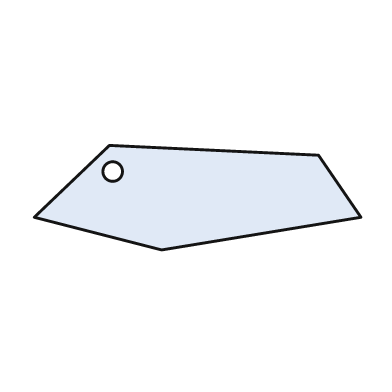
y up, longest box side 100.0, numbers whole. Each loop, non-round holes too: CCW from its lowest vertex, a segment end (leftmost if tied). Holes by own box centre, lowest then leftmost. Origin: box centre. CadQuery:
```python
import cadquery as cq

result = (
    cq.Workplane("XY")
    .moveTo(-11.0, -16.0)
    .lineTo(50.0, -6.0)
    .lineTo(37.0, 13.0)
    .lineTo(-27.0, 16.0)
    .lineTo(-50.0, -6.0)
    .close()
    .moveTo(-26.0, 8.0)
    .circle(3.0)
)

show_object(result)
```